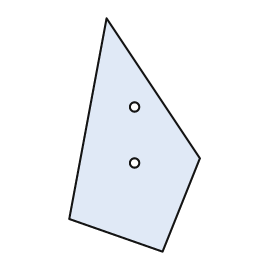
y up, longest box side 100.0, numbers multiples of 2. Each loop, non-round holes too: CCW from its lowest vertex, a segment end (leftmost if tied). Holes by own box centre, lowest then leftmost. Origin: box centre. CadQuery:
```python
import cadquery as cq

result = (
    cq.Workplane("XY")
    .moveTo(12.0, -50.0)
    .lineTo(28.0, -10.0)
    .lineTo(-12.0, 50.0)
    .lineTo(-28.0, -36.0)
    .close()
    .moveTo(0.0, -12.0)
    .circle(2.0)
    .moveTo(0.0, 12.0)
    .circle(2.0)
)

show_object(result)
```